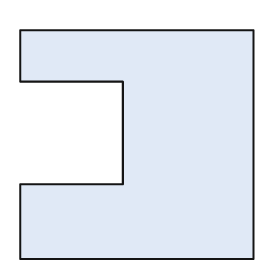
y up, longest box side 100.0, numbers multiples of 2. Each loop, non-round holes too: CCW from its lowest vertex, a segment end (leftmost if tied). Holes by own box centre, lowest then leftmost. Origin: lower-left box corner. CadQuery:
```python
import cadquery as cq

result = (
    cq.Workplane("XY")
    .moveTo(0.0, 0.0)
    .lineTo(100.0, 0.0)
    .lineTo(100.0, 98.0)
    .lineTo(0.0, 98.0)
    .lineTo(0.0, 76.0)
    .lineTo(44.0, 76.0)
    .lineTo(44.0, 32.0)
    .lineTo(0.0, 32.0)
    .close()
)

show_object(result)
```